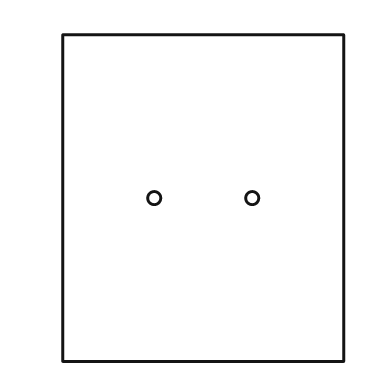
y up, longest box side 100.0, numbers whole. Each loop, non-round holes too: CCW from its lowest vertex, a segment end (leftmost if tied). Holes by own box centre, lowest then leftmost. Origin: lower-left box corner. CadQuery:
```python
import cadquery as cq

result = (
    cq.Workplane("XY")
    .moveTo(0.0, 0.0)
    .lineTo(86.0, 0.0)
    .lineTo(86.0, 100.0)
    .lineTo(0.0, 100.0)
    .close()
    .moveTo(28.0, 50.0)
    .circle(2.0)
    .moveTo(58.0, 50.0)
    .circle(2.0)
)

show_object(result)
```